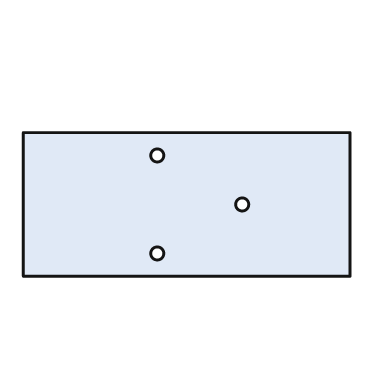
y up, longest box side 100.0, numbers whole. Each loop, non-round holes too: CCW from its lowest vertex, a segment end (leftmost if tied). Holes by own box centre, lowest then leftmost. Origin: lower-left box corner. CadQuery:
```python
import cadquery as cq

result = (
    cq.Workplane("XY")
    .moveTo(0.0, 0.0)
    .lineTo(100.0, 0.0)
    .lineTo(100.0, 44.0)
    .lineTo(0.0, 44.0)
    .close()
    .moveTo(41.0, 7.0)
    .circle(2.0)
    .moveTo(67.0, 22.0)
    .circle(2.0)
    .moveTo(41.0, 37.0)
    .circle(2.0)
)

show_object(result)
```